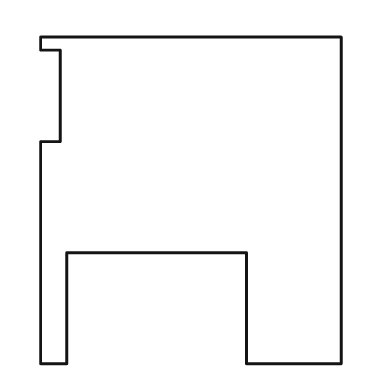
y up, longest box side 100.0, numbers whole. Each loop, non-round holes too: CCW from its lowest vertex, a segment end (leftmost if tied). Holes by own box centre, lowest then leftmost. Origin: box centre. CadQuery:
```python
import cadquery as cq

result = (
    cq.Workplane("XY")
    .moveTo(-46.0, -50.0)
    .lineTo(-38.0, -50.0)
    .lineTo(-38.0, -16.0)
    .lineTo(17.0, -16.0)
    .lineTo(17.0, -50.0)
    .lineTo(46.0, -50.0)
    .lineTo(46.0, 50.0)
    .lineTo(-46.0, 50.0)
    .lineTo(-46.0, 46.0)
    .lineTo(-40.0, 46.0)
    .lineTo(-40.0, 18.0)
    .lineTo(-46.0, 18.0)
    .close()
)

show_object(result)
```